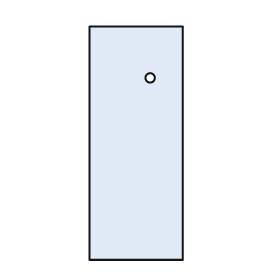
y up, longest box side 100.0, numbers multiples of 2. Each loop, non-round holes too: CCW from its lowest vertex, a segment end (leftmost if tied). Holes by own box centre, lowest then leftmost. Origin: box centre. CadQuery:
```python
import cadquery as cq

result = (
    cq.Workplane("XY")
    .moveTo(-20.0, -50.0)
    .lineTo(20.0, -50.0)
    .lineTo(20.0, 50.0)
    .lineTo(-20.0, 50.0)
    .close()
    .moveTo(6.0, 28.0)
    .circle(2.0)
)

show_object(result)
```